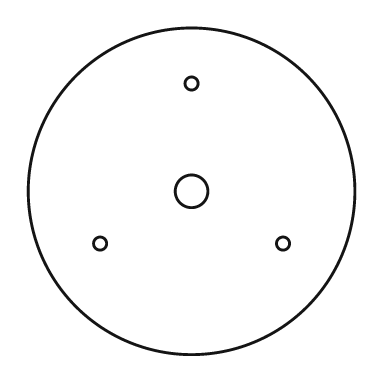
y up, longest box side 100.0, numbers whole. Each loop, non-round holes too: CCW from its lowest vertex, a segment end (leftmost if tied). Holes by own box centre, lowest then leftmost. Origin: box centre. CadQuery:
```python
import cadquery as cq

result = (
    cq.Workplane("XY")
    .moveTo(0.0, 0.0)
    .circle(50.0)
    .moveTo(-28.0, -16.0)
    .circle(2.0)
    .moveTo(28.0, -16.0)
    .circle(2.0)
    .moveTo(0.0, 0.0)
    .circle(5.0)
    .moveTo(0.0, 33.0)
    .circle(2.0)
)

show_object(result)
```